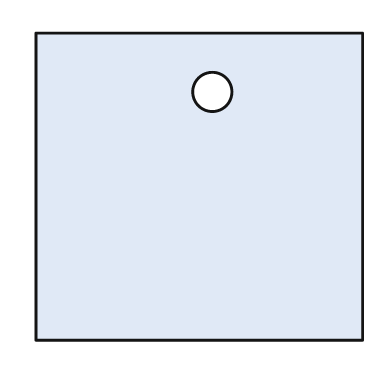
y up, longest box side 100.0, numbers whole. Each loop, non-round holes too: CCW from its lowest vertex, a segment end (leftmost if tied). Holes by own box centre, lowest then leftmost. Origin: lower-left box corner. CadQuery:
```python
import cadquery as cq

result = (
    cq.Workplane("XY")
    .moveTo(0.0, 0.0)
    .lineTo(100.0, 0.0)
    .lineTo(100.0, 94.0)
    .lineTo(0.0, 94.0)
    .close()
    .moveTo(54.0, 76.0)
    .circle(6.0)
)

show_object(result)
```